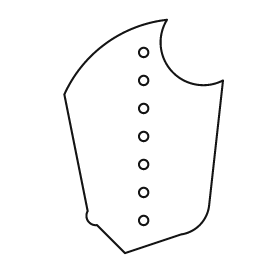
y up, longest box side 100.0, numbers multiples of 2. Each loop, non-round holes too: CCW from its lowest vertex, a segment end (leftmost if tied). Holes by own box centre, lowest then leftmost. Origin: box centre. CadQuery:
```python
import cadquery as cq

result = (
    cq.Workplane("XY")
    .moveTo(-8.0, -50.0)
    .lineTo(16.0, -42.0)
    .threePointArc((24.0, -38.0), (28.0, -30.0))
    .lineTo(34.0, 24.0)
    .threePointArc((12.0, 28.0), (10.0, 50.0))
    .threePointArc((-16.0, 40.0), (-34.0, 18.0))
    .lineTo(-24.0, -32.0)
    .threePointArc((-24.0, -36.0), (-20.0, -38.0))
    .close()
    .moveTo(0.0, -36.0)
    .circle(2.0)
    .moveTo(0.0, -24.0)
    .circle(2.0)
    .moveTo(0.0, -12.0)
    .circle(2.0)
    .moveTo(0.0, 0.0)
    .circle(2.0)
    .moveTo(0.0, 12.0)
    .circle(2.0)
    .moveTo(0.0, 24.0)
    .circle(2.0)
    .moveTo(0.0, 36.0)
    .circle(2.0)
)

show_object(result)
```